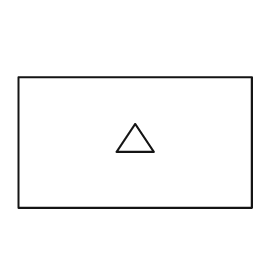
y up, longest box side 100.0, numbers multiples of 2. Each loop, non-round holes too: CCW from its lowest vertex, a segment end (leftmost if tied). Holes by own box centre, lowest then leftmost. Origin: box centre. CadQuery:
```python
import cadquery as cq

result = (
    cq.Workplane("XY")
    .moveTo(-50.0, -28.0)
    .lineTo(50.0, -28.0)
    .lineTo(50.0, 28.0)
    .lineTo(-50.0, 28.0)
    .close()
    .moveTo(-8.0, -4.0)
    .lineTo(8.0, -4.0)
    .lineTo(0.0, 8.0)
    .close()
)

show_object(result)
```